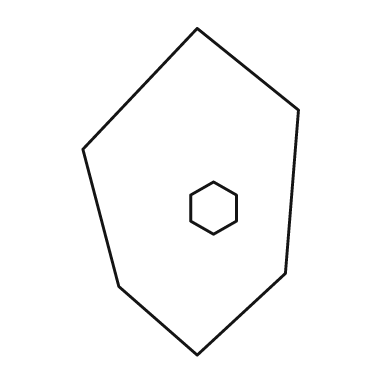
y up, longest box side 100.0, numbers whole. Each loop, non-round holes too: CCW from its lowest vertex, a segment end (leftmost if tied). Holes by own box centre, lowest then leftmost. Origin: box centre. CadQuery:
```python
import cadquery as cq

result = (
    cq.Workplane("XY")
    .moveTo(2.0, -50.0)
    .lineTo(29.0, -25.0)
    .lineTo(33.0, 25.0)
    .lineTo(2.0, 50.0)
    .lineTo(-33.0, 13.0)
    .lineTo(-22.0, -29.0)
    .close()
    .moveTo(7.0, -13.0)
    .lineTo(14.0, -9.0)
    .lineTo(14.0, -1.0)
    .lineTo(7.0, 3.0)
    .lineTo(0.0, -1.0)
    .lineTo(0.0, -9.0)
    .close()
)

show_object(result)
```